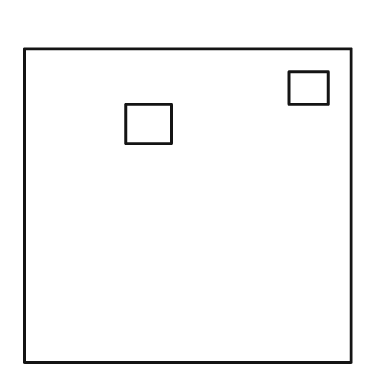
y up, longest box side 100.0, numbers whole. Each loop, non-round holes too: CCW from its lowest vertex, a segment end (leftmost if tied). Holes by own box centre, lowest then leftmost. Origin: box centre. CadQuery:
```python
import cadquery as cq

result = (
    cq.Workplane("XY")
    .moveTo(-50.0, -48.0)
    .lineTo(50.0, -48.0)
    .lineTo(50.0, 48.0)
    .lineTo(-50.0, 48.0)
    .close()
    .moveTo(-19.0, 19.0)
    .lineTo(-5.0, 19.0)
    .lineTo(-5.0, 31.0)
    .lineTo(-19.0, 31.0)
    .close()
    .moveTo(31.0, 31.0)
    .lineTo(43.0, 31.0)
    .lineTo(43.0, 41.0)
    .lineTo(31.0, 41.0)
    .close()
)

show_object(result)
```